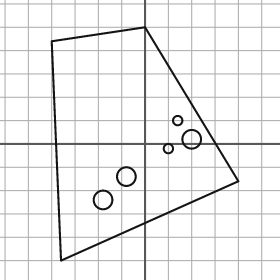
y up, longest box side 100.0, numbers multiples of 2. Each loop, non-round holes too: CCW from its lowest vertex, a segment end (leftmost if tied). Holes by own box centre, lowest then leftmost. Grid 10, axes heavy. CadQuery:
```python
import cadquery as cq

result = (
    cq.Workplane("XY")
    .moveTo(-36.0, -50.0)
    .lineTo(40.0, -16.0)
    .lineTo(0.0, 50.0)
    .lineTo(-40.0, 44.0)
    .close()
    .moveTo(-18.0, -24.0)
    .circle(4.0)
    .moveTo(-8.0, -14.0)
    .circle(4.0)
    .moveTo(10.0, -2.0)
    .circle(2.0)
    .moveTo(20.0, 2.0)
    .circle(4.0)
    .moveTo(14.0, 10.0)
    .circle(2.0)
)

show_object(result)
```